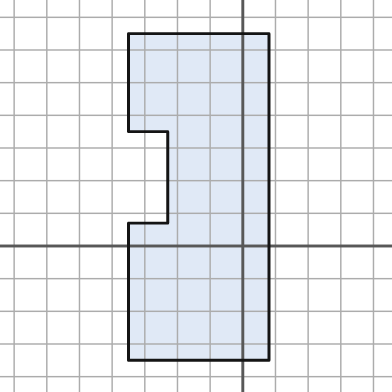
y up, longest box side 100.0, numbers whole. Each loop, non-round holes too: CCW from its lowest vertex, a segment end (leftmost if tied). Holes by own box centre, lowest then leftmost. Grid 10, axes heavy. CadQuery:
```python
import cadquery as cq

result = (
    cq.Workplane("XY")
    .moveTo(-35.0, -35.0)
    .lineTo(8.0, -35.0)
    .lineTo(8.0, 65.0)
    .lineTo(-35.0, 65.0)
    .lineTo(-35.0, 35.0)
    .lineTo(-23.0, 35.0)
    .lineTo(-23.0, 7.0)
    .lineTo(-35.0, 7.0)
    .close()
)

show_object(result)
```